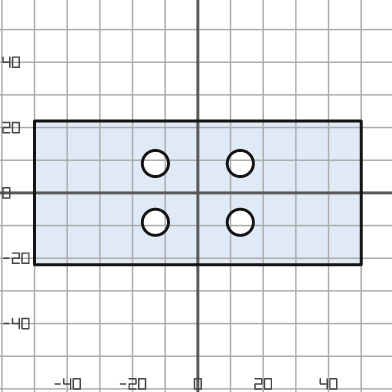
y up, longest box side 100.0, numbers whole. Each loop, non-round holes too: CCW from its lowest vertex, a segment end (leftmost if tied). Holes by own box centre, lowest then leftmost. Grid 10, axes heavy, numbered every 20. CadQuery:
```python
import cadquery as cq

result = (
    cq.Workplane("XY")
    .moveTo(-50.0, -22.0)
    .lineTo(50.0, -22.0)
    .lineTo(50.0, 22.0)
    .lineTo(-50.0, 22.0)
    .close()
    .moveTo(-13.0, -9.0)
    .circle(4.0)
    .moveTo(13.0, -9.0)
    .circle(4.0)
    .moveTo(-13.0, 9.0)
    .circle(4.0)
    .moveTo(13.0, 9.0)
    .circle(4.0)
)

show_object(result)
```